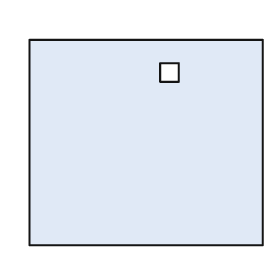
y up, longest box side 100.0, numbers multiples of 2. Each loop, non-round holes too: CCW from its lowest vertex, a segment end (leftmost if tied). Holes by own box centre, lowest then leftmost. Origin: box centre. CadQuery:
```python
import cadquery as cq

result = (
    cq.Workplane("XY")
    .moveTo(-50.0, -44.0)
    .lineTo(50.0, -44.0)
    .lineTo(50.0, 44.0)
    .lineTo(-50.0, 44.0)
    .close()
    .moveTo(6.0, 26.0)
    .lineTo(14.0, 26.0)
    .lineTo(14.0, 34.0)
    .lineTo(6.0, 34.0)
    .close()
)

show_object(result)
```